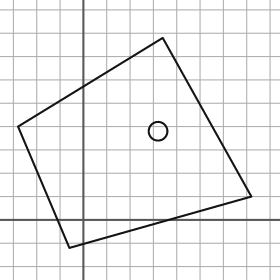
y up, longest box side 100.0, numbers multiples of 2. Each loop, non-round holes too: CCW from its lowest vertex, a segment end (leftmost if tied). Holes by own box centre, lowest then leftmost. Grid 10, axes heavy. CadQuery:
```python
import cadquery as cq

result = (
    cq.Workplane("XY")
    .moveTo(-6.0, -12.0)
    .lineTo(72.0, 10.0)
    .lineTo(34.0, 78.0)
    .lineTo(-28.0, 40.0)
    .close()
    .moveTo(32.0, 38.0)
    .circle(4.0)
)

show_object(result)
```